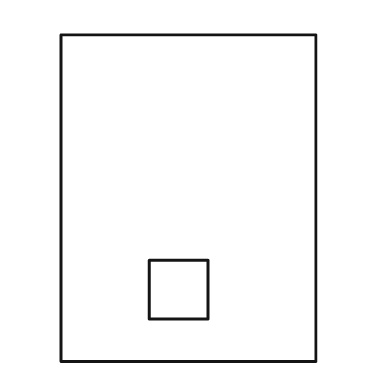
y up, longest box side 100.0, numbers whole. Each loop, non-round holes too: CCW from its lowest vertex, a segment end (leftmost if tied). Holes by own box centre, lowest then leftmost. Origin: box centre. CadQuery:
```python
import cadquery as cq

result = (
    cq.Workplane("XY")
    .moveTo(-39.0, -50.0)
    .lineTo(39.0, -50.0)
    .lineTo(39.0, 50.0)
    .lineTo(-39.0, 50.0)
    .close()
    .moveTo(-12.0, -37.0)
    .lineTo(6.0, -37.0)
    .lineTo(6.0, -19.0)
    .lineTo(-12.0, -19.0)
    .close()
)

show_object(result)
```